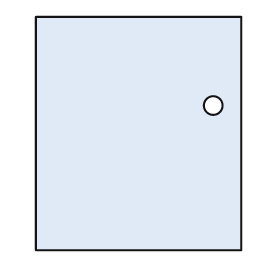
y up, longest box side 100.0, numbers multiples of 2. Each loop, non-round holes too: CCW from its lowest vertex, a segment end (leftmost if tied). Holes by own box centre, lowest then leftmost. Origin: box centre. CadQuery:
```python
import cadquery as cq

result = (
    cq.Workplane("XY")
    .moveTo(-44.0, -50.0)
    .lineTo(44.0, -50.0)
    .lineTo(44.0, 50.0)
    .lineTo(-44.0, 50.0)
    .close()
    .moveTo(32.0, 12.0)
    .circle(4.0)
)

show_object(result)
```